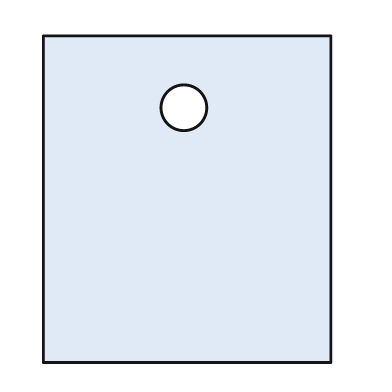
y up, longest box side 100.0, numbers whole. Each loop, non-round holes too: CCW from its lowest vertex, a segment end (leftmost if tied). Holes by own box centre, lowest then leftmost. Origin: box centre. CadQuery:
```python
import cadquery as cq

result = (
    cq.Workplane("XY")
    .moveTo(-44.0, -50.0)
    .lineTo(44.0, -50.0)
    .lineTo(44.0, 50.0)
    .lineTo(-44.0, 50.0)
    .close()
    .moveTo(-1.0, 28.0)
    .circle(7.0)
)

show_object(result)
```